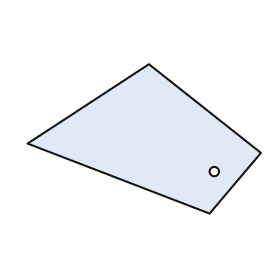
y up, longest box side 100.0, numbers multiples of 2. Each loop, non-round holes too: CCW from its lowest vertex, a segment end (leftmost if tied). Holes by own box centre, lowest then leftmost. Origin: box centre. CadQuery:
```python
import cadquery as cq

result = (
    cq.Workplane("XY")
    .moveTo(28.0, -32.0)
    .lineTo(50.0, -6.0)
    .lineTo(2.0, 32.0)
    .lineTo(-50.0, -2.0)
    .close()
    .moveTo(30.0, -14.0)
    .circle(2.0)
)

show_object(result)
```